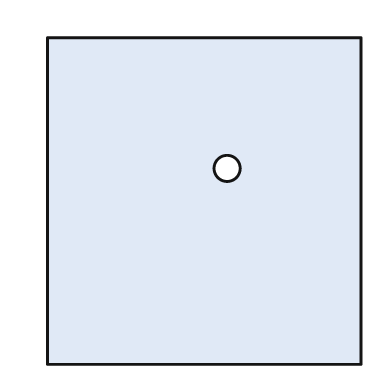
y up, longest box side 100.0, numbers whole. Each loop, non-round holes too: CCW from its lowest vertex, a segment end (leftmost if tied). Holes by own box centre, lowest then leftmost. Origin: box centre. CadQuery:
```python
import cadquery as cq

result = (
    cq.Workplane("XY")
    .moveTo(-48.0, -50.0)
    .lineTo(48.0, -50.0)
    .lineTo(48.0, 50.0)
    .lineTo(-48.0, 50.0)
    .close()
    .moveTo(7.0, 10.0)
    .circle(4.0)
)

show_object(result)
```